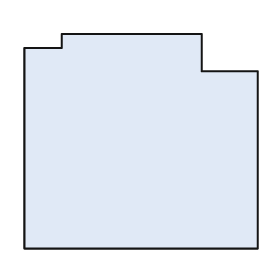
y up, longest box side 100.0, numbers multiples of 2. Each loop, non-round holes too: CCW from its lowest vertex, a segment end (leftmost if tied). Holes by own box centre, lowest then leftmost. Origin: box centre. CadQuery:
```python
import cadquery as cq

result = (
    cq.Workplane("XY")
    .moveTo(-50.0, -46.0)
    .lineTo(50.0, -46.0)
    .lineTo(50.0, 30.0)
    .lineTo(26.0, 30.0)
    .lineTo(26.0, 46.0)
    .lineTo(-34.0, 46.0)
    .lineTo(-34.0, 40.0)
    .lineTo(-50.0, 40.0)
    .close()
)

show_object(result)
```